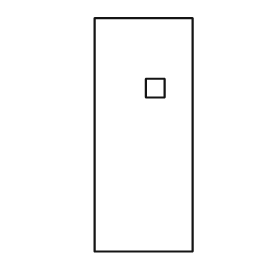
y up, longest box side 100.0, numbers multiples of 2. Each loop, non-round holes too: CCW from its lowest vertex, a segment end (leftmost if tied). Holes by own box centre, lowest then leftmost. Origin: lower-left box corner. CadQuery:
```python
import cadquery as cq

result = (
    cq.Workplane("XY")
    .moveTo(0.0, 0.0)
    .lineTo(42.0, 0.0)
    .lineTo(42.0, 100.0)
    .lineTo(0.0, 100.0)
    .close()
    .moveTo(22.0, 66.0)
    .lineTo(30.0, 66.0)
    .lineTo(30.0, 74.0)
    .lineTo(22.0, 74.0)
    .close()
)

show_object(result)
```